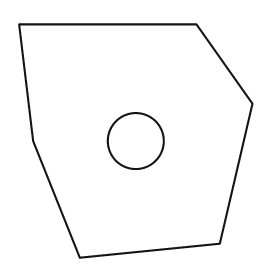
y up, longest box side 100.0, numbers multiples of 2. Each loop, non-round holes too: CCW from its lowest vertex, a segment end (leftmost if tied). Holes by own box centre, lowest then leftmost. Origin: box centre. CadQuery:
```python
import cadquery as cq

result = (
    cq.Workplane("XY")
    .moveTo(-24.0, -50.0)
    .lineTo(36.0, -44.0)
    .lineTo(50.0, 16.0)
    .lineTo(26.0, 50.0)
    .lineTo(-50.0, 50.0)
    .lineTo(-44.0, 0.0)
    .close()
    .moveTo(0.0, 0.0)
    .circle(12.0)
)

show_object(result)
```